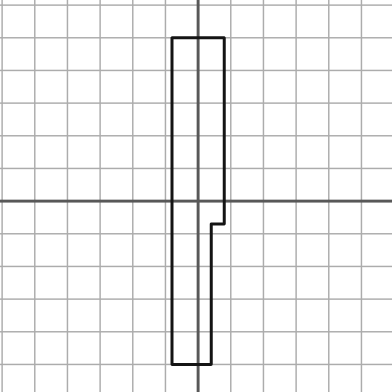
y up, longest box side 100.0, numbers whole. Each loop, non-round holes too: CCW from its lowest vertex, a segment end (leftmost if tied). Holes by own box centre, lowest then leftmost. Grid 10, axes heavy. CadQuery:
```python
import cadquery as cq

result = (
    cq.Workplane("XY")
    .moveTo(-8.0, -50.0)
    .lineTo(4.0, -50.0)
    .lineTo(4.0, -7.0)
    .lineTo(8.0, -7.0)
    .lineTo(8.0, 50.0)
    .lineTo(-8.0, 50.0)
    .close()
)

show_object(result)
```